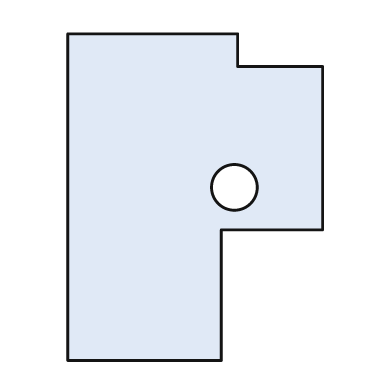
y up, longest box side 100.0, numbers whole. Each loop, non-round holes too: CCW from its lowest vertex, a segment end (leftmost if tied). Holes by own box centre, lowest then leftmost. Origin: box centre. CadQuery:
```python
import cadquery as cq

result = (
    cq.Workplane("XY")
    .moveTo(-39.0, -50.0)
    .lineTo(8.0, -50.0)
    .lineTo(8.0, -10.0)
    .lineTo(39.0, -10.0)
    .lineTo(39.0, 40.0)
    .lineTo(13.0, 40.0)
    .lineTo(13.0, 50.0)
    .lineTo(-39.0, 50.0)
    .close()
    .moveTo(12.0, 3.0)
    .circle(7.0)
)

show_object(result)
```